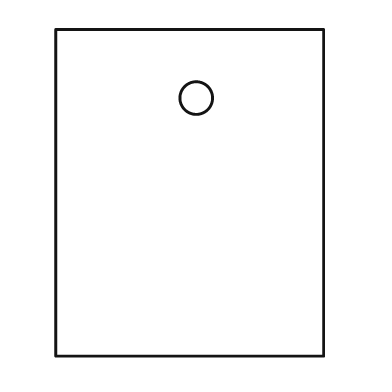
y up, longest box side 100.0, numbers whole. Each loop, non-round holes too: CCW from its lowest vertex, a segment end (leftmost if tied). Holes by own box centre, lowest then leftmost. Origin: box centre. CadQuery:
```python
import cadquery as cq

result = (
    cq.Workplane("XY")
    .moveTo(-41.0, -50.0)
    .lineTo(41.0, -50.0)
    .lineTo(41.0, 50.0)
    .lineTo(-41.0, 50.0)
    .close()
    .moveTo(2.0, 29.0)
    .circle(5.0)
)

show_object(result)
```